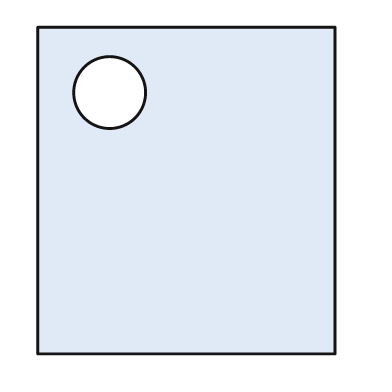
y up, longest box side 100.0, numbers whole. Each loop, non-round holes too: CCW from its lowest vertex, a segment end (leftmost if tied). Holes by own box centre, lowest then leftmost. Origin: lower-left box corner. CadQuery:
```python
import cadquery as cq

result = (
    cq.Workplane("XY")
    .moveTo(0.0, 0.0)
    .lineTo(91.0, 0.0)
    .lineTo(91.0, 100.0)
    .lineTo(0.0, 100.0)
    .close()
    .moveTo(22.0, 80.0)
    .circle(11.0)
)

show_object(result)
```